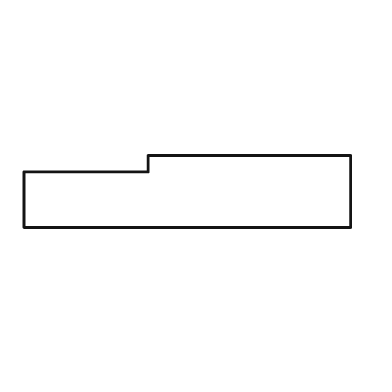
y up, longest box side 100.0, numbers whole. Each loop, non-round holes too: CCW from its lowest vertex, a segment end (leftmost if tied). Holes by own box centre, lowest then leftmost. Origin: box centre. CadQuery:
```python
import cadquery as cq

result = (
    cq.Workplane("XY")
    .moveTo(-50.0, -11.0)
    .lineTo(50.0, -11.0)
    .lineTo(50.0, 11.0)
    .lineTo(-12.0, 11.0)
    .lineTo(-12.0, 6.0)
    .lineTo(-50.0, 6.0)
    .close()
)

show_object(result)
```